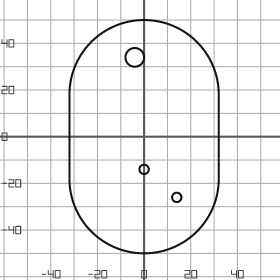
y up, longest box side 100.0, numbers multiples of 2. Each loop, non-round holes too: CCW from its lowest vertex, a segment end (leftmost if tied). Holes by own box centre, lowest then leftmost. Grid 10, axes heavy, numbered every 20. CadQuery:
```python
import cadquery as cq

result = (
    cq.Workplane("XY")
    .moveTo(-32.0, -18.0)
    .threePointArc((0.0, -50.0), (32.0, -18.0))
    .lineTo(32.0, 18.0)
    .threePointArc((0.0, 50.0), (-32.0, 18.0))
    .close()
    .moveTo(14.0, -26.0)
    .circle(2.0)
    .moveTo(0.0, -14.0)
    .circle(2.0)
    .moveTo(-4.0, 34.0)
    .circle(4.0)
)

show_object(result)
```